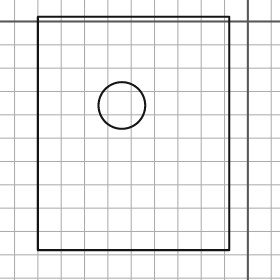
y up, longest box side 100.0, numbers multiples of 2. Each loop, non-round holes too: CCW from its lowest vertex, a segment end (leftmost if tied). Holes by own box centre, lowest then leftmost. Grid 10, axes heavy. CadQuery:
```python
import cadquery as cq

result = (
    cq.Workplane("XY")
    .moveTo(-90.0, -98.0)
    .lineTo(-8.0, -98.0)
    .lineTo(-8.0, 2.0)
    .lineTo(-90.0, 2.0)
    .close()
    .moveTo(-54.0, -36.0)
    .circle(10.0)
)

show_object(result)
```